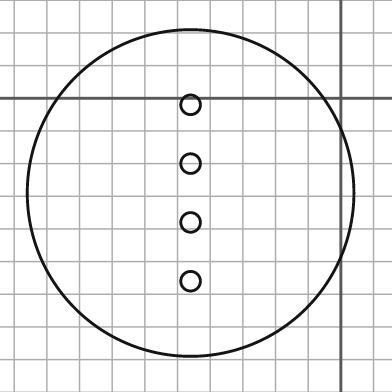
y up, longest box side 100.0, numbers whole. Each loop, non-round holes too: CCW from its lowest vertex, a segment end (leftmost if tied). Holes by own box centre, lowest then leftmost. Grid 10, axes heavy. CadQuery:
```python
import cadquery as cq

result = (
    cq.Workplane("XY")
    .moveTo(-46.0, -29.0)
    .circle(50.0)
    .moveTo(-46.0, -56.0)
    .circle(3.0)
    .moveTo(-46.0, -38.0)
    .circle(3.0)
    .moveTo(-46.0, -20.0)
    .circle(3.0)
    .moveTo(-46.0, -2.0)
    .circle(3.0)
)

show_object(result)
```